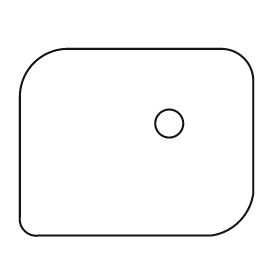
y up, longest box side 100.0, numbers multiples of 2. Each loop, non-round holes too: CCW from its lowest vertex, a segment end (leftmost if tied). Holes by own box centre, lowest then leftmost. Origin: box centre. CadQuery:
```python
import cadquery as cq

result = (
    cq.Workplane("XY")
    .moveTo(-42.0, -40.0)
    .lineTo(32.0, -40.0)
    .threePointArc((44.0, -34.0), (50.0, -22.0))
    .lineTo(50.0, 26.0)
    .threePointArc((46.0, 36.0), (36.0, 40.0))
    .lineTo(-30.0, 40.0)
    .threePointArc((-44.0, 34.0), (-50.0, 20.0))
    .lineTo(-50.0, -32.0)
    .threePointArc((-48.0, -38.0), (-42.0, -40.0))
    .close()
    .moveTo(14.0, 8.0)
    .circle(6.0)
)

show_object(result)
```